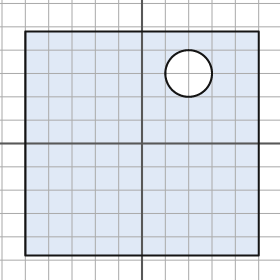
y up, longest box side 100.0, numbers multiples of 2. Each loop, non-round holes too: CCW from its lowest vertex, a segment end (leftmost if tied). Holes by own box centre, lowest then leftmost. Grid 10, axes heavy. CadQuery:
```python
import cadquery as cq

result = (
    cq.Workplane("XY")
    .moveTo(-50.0, -48.0)
    .lineTo(50.0, -48.0)
    .lineTo(50.0, 48.0)
    .lineTo(-50.0, 48.0)
    .close()
    .moveTo(20.0, 30.0)
    .circle(10.0)
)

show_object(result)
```